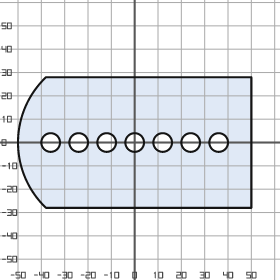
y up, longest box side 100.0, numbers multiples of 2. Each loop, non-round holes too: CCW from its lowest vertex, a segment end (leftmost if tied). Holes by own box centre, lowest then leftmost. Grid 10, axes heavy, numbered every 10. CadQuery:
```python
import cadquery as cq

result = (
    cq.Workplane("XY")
    .moveTo(-38.0, -28.0)
    .lineTo(50.0, -28.0)
    .lineTo(50.0, 28.0)
    .lineTo(-38.0, 28.0)
    .threePointArc((-50.0, 0.0), (-38.0, -28.0))
    .close()
    .moveTo(-36.0, 0.0)
    .circle(4.0)
    .moveTo(-24.0, 0.0)
    .circle(4.0)
    .moveTo(-12.0, 0.0)
    .circle(4.0)
    .moveTo(0.0, 0.0)
    .circle(4.0)
    .moveTo(12.0, 0.0)
    .circle(4.0)
    .moveTo(24.0, 0.0)
    .circle(4.0)
    .moveTo(36.0, 0.0)
    .circle(4.0)
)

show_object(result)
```